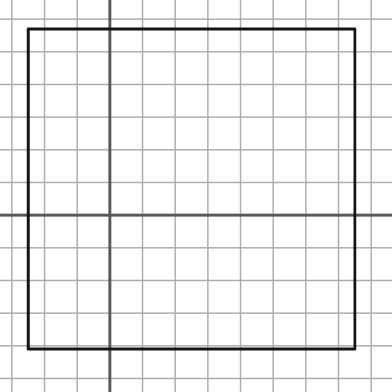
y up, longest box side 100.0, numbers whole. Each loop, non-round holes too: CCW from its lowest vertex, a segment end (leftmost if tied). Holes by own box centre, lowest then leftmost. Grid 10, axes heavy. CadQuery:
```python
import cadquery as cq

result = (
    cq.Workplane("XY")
    .moveTo(-25.0, -41.0)
    .lineTo(75.0, -41.0)
    .lineTo(75.0, 57.0)
    .lineTo(-25.0, 57.0)
    .close()
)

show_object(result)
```